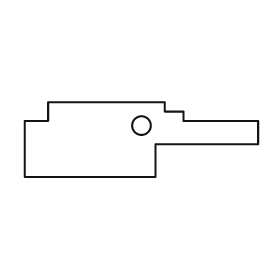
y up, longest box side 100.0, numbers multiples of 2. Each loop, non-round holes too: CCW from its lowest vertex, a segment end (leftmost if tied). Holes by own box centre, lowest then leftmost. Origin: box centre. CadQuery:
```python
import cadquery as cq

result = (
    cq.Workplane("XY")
    .moveTo(-50.0, -16.0)
    .lineTo(6.0, -16.0)
    .lineTo(6.0, -2.0)
    .lineTo(50.0, -2.0)
    .lineTo(50.0, 8.0)
    .lineTo(18.0, 8.0)
    .lineTo(18.0, 12.0)
    .lineTo(10.0, 12.0)
    .lineTo(10.0, 16.0)
    .lineTo(-40.0, 16.0)
    .lineTo(-40.0, 8.0)
    .lineTo(-50.0, 8.0)
    .close()
    .moveTo(0.0, 6.0)
    .circle(4.0)
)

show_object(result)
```